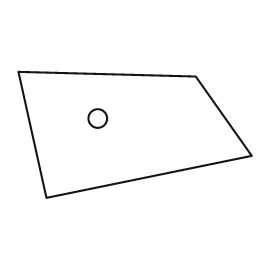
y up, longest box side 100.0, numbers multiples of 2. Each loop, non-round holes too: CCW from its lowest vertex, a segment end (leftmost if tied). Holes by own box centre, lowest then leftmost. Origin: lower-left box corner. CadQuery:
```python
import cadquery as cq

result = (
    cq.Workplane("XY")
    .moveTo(12.0, 0.0)
    .lineTo(100.0, 18.0)
    .lineTo(76.0, 52.0)
    .lineTo(0.0, 54.0)
    .close()
    .moveTo(34.0, 34.0)
    .circle(4.0)
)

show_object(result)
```